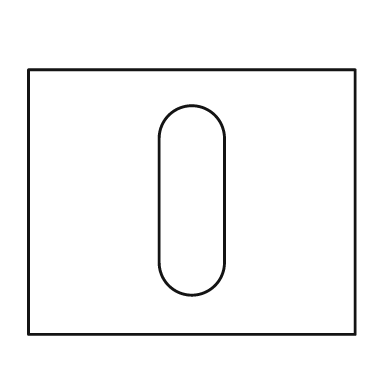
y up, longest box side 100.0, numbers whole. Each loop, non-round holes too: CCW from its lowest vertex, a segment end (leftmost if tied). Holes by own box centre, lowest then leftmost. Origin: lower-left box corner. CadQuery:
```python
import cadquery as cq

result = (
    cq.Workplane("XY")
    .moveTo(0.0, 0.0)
    .lineTo(100.0, 0.0)
    .lineTo(100.0, 81.0)
    .lineTo(0.0, 81.0)
    .close()
    .moveTo(40.0, 22.0)
    .threePointArc((50.0, 12.0), (60.0, 22.0))
    .lineTo(60.0, 60.0)
    .threePointArc((50.0, 70.0), (40.0, 60.0))
    .close()
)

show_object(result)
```